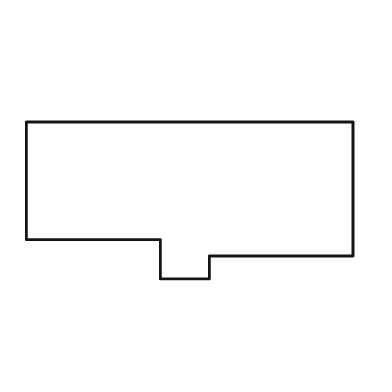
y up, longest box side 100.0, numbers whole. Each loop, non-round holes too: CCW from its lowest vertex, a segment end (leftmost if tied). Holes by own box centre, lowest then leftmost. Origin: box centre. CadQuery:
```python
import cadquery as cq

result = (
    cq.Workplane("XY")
    .moveTo(-9.0, -24.0)
    .lineTo(6.0, -24.0)
    .lineTo(6.0, -17.0)
    .lineTo(50.0, -17.0)
    .lineTo(50.0, 24.0)
    .lineTo(-50.0, 24.0)
    .lineTo(-50.0, -12.0)
    .lineTo(-9.0, -12.0)
    .close()
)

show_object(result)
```